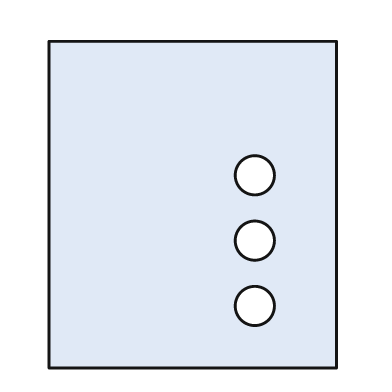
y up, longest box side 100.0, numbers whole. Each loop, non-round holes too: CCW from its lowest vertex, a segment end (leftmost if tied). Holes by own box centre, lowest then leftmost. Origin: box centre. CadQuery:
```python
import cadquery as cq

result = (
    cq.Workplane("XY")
    .moveTo(-44.0, -50.0)
    .lineTo(44.0, -50.0)
    .lineTo(44.0, 50.0)
    .lineTo(-44.0, 50.0)
    .close()
    .moveTo(19.0, -31.0)
    .circle(6.0)
    .moveTo(19.0, -11.0)
    .circle(6.0)
    .moveTo(19.0, 9.0)
    .circle(6.0)
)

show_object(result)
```